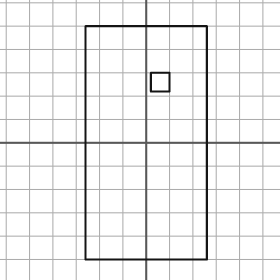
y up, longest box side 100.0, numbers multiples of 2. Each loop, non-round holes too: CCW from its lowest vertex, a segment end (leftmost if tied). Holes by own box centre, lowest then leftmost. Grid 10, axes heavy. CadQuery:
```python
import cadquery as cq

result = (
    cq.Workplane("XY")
    .moveTo(-26.0, -50.0)
    .lineTo(26.0, -50.0)
    .lineTo(26.0, 50.0)
    .lineTo(-26.0, 50.0)
    .close()
    .moveTo(2.0, 22.0)
    .lineTo(10.0, 22.0)
    .lineTo(10.0, 30.0)
    .lineTo(2.0, 30.0)
    .close()
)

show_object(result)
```